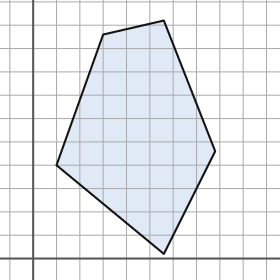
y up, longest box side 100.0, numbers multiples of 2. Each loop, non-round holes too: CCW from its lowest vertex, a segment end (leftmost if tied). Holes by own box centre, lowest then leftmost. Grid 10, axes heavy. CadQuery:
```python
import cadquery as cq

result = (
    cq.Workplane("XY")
    .moveTo(56.0, 2.0)
    .lineTo(78.0, 46.0)
    .lineTo(56.0, 102.0)
    .lineTo(30.0, 96.0)
    .lineTo(10.0, 40.0)
    .close()
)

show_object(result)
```